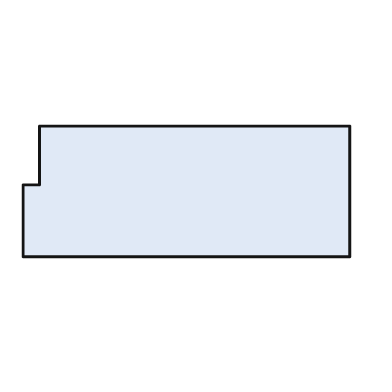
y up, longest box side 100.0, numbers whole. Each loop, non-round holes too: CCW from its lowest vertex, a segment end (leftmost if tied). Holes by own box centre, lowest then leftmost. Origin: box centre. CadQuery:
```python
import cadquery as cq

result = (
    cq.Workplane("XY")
    .moveTo(-50.0, -20.0)
    .lineTo(50.0, -20.0)
    .lineTo(50.0, 20.0)
    .lineTo(-45.0, 20.0)
    .lineTo(-45.0, 2.0)
    .lineTo(-50.0, 2.0)
    .close()
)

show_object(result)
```